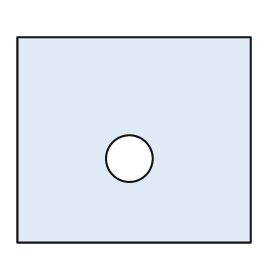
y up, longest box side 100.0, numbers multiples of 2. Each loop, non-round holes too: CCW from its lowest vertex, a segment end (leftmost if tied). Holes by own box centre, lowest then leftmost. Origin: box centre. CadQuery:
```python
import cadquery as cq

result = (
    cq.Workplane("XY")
    .moveTo(-50.0, -44.0)
    .lineTo(50.0, -44.0)
    .lineTo(50.0, 44.0)
    .lineTo(-50.0, 44.0)
    .close()
    .moveTo(-2.0, -8.0)
    .circle(10.0)
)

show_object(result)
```